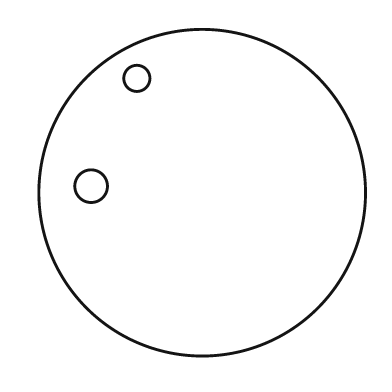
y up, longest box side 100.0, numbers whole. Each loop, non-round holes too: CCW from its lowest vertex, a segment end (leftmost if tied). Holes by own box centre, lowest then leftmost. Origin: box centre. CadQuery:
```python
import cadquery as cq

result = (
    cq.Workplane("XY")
    .moveTo(0.0, 0.0)
    .circle(50.0)
    .moveTo(-34.0, 2.0)
    .circle(5.0)
    .moveTo(-20.0, 35.0)
    .circle(4.0)
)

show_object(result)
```